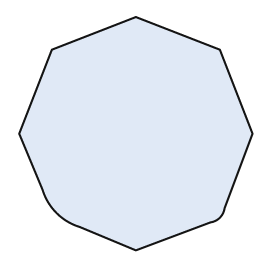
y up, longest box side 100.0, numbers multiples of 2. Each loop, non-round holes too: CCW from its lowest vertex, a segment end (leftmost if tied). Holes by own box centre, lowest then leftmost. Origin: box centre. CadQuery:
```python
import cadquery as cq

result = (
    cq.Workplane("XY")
    .moveTo(0.0, -50.0)
    .lineTo(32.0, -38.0)
    .threePointArc((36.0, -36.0), (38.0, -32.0))
    .lineTo(50.0, 0.0)
    .lineTo(36.0, 36.0)
    .lineTo(0.0, 50.0)
    .lineTo(-36.0, 36.0)
    .lineTo(-50.0, 0.0)
    .lineTo(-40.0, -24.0)
    .threePointArc((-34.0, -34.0), (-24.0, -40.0))
    .close()
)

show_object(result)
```